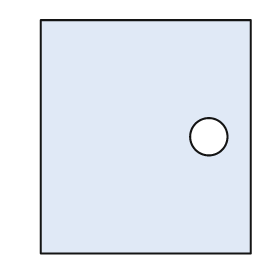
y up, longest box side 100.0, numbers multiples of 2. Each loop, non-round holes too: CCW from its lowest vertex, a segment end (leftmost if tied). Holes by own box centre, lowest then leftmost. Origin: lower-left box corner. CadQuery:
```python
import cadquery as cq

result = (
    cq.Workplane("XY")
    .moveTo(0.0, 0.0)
    .lineTo(90.0, 0.0)
    .lineTo(90.0, 100.0)
    .lineTo(0.0, 100.0)
    .close()
    .moveTo(72.0, 50.0)
    .circle(8.0)
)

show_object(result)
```